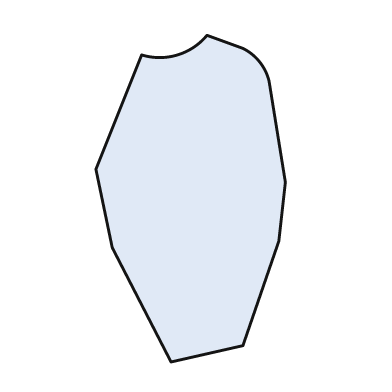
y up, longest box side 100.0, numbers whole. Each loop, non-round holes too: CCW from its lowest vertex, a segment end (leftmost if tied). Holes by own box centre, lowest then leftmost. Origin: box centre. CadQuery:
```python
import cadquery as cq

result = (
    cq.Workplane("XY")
    .moveTo(-6.0, -50.0)
    .lineTo(16.0, -45.0)
    .lineTo(27.0, -13.0)
    .lineTo(29.0, 5.0)
    .lineTo(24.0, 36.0)
    .threePointArc((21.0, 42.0), (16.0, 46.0))
    .lineTo(5.0, 50.0)
    .threePointArc((-4.0, 44.0), (-15.0, 44.0))
    .lineTo(-29.0, 9.0)
    .lineTo(-24.0, -15.0)
    .close()
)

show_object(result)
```